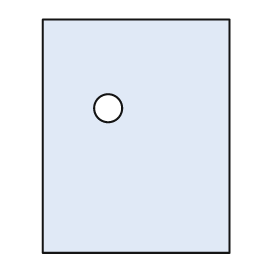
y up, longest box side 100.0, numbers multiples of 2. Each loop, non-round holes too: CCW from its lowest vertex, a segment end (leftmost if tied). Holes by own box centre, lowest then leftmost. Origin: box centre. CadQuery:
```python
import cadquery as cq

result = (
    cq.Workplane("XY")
    .moveTo(-40.0, -50.0)
    .lineTo(40.0, -50.0)
    .lineTo(40.0, 50.0)
    .lineTo(-40.0, 50.0)
    .close()
    .moveTo(-12.0, 12.0)
    .circle(6.0)
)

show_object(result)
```